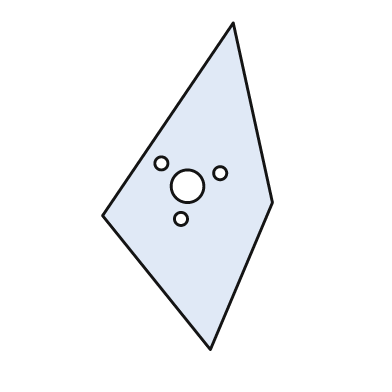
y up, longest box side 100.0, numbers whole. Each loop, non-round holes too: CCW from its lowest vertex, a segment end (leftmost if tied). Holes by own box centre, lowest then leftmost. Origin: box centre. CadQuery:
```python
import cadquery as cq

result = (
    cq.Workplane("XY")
    .moveTo(7.0, -50.0)
    .lineTo(26.0, -5.0)
    .lineTo(14.0, 50.0)
    .lineTo(-26.0, -9.0)
    .close()
    .moveTo(-2.0, -10.0)
    .circle(2.0)
    .moveTo(0.0, 0.0)
    .circle(5.0)
    .moveTo(10.0, 4.0)
    .circle(2.0)
    .moveTo(-8.0, 7.0)
    .circle(2.0)
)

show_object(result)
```